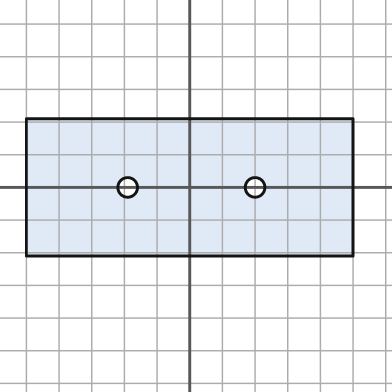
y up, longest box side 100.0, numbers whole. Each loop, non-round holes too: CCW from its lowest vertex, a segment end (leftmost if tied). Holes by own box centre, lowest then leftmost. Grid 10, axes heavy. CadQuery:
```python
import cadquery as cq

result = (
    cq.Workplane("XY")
    .moveTo(-50.0, -21.0)
    .lineTo(50.0, -21.0)
    .lineTo(50.0, 21.0)
    .lineTo(-50.0, 21.0)
    .close()
    .moveTo(-19.0, 0.0)
    .circle(3.0)
    .moveTo(20.0, 0.0)
    .circle(3.0)
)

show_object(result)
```